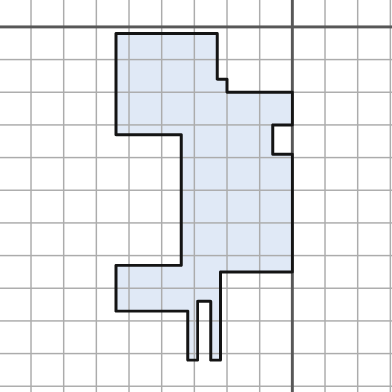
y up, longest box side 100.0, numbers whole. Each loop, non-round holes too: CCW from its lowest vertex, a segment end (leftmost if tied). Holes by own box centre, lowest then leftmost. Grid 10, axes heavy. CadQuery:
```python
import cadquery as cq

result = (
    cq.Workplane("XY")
    .moveTo(-32.0, -102.0)
    .lineTo(-29.0, -102.0)
    .lineTo(-29.0, -84.0)
    .lineTo(-25.0, -84.0)
    .lineTo(-25.0, -102.0)
    .lineTo(-22.0, -102.0)
    .lineTo(-22.0, -75.0)
    .lineTo(0.0, -75.0)
    .lineTo(0.0, -39.0)
    .lineTo(-6.0, -39.0)
    .lineTo(-6.0, -30.0)
    .lineTo(0.0, -30.0)
    .lineTo(0.0, -20.0)
    .lineTo(-20.0, -20.0)
    .lineTo(-20.0, -16.0)
    .lineTo(-23.0, -16.0)
    .lineTo(-23.0, -2.0)
    .lineTo(-54.0, -2.0)
    .lineTo(-54.0, -33.0)
    .lineTo(-34.0, -33.0)
    .lineTo(-34.0, -73.0)
    .lineTo(-54.0, -73.0)
    .lineTo(-54.0, -87.0)
    .lineTo(-32.0, -87.0)
    .close()
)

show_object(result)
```